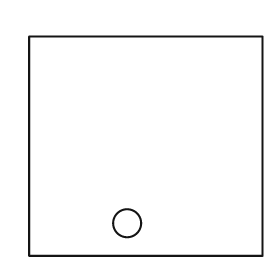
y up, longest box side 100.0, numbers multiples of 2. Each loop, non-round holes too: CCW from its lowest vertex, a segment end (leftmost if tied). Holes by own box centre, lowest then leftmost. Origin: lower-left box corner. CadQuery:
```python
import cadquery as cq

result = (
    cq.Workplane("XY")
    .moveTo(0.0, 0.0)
    .lineTo(100.0, 0.0)
    .lineTo(100.0, 94.0)
    .lineTo(0.0, 94.0)
    .close()
    .moveTo(42.0, 14.0)
    .circle(6.0)
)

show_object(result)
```